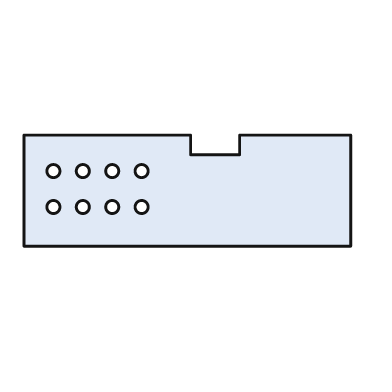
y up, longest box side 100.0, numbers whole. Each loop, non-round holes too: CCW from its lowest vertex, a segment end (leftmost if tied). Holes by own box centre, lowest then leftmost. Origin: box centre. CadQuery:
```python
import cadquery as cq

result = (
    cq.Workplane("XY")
    .moveTo(-50.0, -17.0)
    .lineTo(50.0, -17.0)
    .lineTo(50.0, 17.0)
    .lineTo(16.0, 17.0)
    .lineTo(16.0, 11.0)
    .lineTo(1.0, 11.0)
    .lineTo(1.0, 17.0)
    .lineTo(-50.0, 17.0)
    .close()
    .moveTo(-41.0, -5.0)
    .circle(2.0)
    .moveTo(-32.0, -5.0)
    .circle(2.0)
    .moveTo(-23.0, -5.0)
    .circle(2.0)
    .moveTo(-14.0, -5.0)
    .circle(2.0)
    .moveTo(-41.0, 6.0)
    .circle(2.0)
    .moveTo(-32.0, 6.0)
    .circle(2.0)
    .moveTo(-23.0, 6.0)
    .circle(2.0)
    .moveTo(-14.0, 6.0)
    .circle(2.0)
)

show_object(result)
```